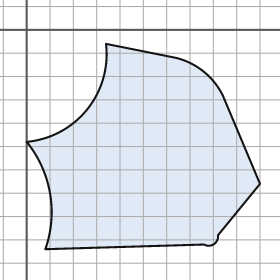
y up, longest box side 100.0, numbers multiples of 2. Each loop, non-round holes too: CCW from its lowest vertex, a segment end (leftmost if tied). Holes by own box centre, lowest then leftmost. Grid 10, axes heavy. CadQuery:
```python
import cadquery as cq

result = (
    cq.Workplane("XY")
    .moveTo(8.0, -94.0)
    .lineTo(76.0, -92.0)
    .threePointArc((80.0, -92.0), (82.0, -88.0))
    .lineTo(100.0, -66.0)
    .lineTo(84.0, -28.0)
    .threePointArc((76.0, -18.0), (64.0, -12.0))
    .lineTo(34.0, -6.0)
    .threePointArc((26.0, -34.0), (0.0, -48.0))
    .threePointArc((10.0, -70.0), (8.0, -94.0))
    .close()
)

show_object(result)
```